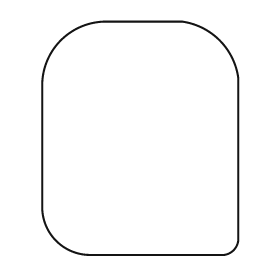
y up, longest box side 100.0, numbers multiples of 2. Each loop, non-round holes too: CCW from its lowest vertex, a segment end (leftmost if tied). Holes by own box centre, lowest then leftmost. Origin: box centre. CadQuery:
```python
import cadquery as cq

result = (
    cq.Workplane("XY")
    .moveTo(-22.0, -50.0)
    .lineTo(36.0, -50.0)
    .threePointArc((40.0, -48.0), (42.0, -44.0))
    .lineTo(42.0, 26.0)
    .threePointArc((34.0, 42.0), (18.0, 50.0))
    .lineTo(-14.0, 50.0)
    .threePointArc((-34.0, 42.0), (-42.0, 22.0))
    .lineTo(-42.0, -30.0)
    .threePointArc((-36.0, -44.0), (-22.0, -50.0))
    .close()
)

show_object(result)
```